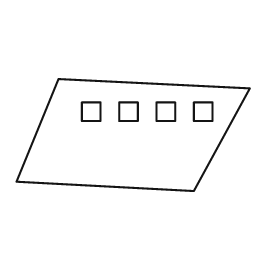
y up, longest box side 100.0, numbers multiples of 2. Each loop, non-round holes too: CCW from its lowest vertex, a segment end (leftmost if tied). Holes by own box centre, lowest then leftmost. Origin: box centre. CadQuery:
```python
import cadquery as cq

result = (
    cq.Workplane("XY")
    .moveTo(26.0, -24.0)
    .lineTo(50.0, 20.0)
    .lineTo(-32.0, 24.0)
    .lineTo(-50.0, -20.0)
    .close()
    .moveTo(-22.0, 6.0)
    .lineTo(-14.0, 6.0)
    .lineTo(-14.0, 14.0)
    .lineTo(-22.0, 14.0)
    .close()
    .moveTo(-6.0, 6.0)
    .lineTo(2.0, 6.0)
    .lineTo(2.0, 14.0)
    .lineTo(-6.0, 14.0)
    .close()
    .moveTo(10.0, 6.0)
    .lineTo(18.0, 6.0)
    .lineTo(18.0, 14.0)
    .lineTo(10.0, 14.0)
    .close()
    .moveTo(26.0, 6.0)
    .lineTo(34.0, 6.0)
    .lineTo(34.0, 14.0)
    .lineTo(26.0, 14.0)
    .close()
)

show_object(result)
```